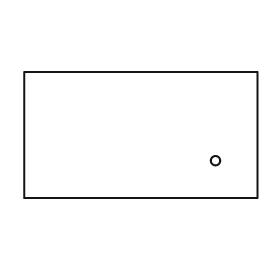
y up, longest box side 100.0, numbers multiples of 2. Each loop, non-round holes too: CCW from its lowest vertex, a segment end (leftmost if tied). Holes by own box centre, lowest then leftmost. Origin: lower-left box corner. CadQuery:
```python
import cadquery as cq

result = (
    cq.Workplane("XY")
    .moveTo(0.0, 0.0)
    .lineTo(100.0, 0.0)
    .lineTo(100.0, 54.0)
    .lineTo(0.0, 54.0)
    .close()
    .moveTo(82.0, 16.0)
    .circle(2.0)
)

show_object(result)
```